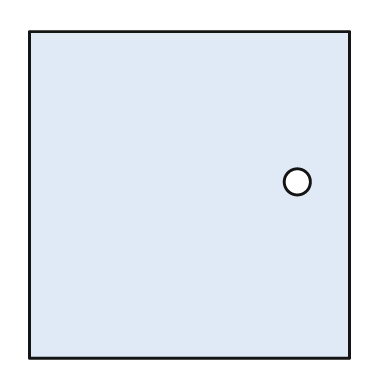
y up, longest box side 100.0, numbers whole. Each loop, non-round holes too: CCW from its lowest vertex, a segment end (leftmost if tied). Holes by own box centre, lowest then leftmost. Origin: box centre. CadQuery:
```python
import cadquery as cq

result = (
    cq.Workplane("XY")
    .moveTo(-49.0, -50.0)
    .lineTo(49.0, -50.0)
    .lineTo(49.0, 50.0)
    .lineTo(-49.0, 50.0)
    .close()
    .moveTo(33.0, 4.0)
    .circle(4.0)
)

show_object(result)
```